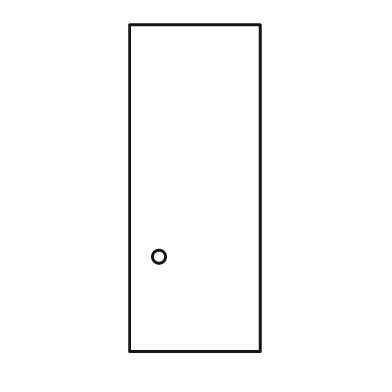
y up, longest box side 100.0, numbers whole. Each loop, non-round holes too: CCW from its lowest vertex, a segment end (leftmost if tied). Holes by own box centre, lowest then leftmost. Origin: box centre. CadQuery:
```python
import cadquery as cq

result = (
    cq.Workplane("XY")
    .moveTo(-20.0, -50.0)
    .lineTo(20.0, -50.0)
    .lineTo(20.0, 50.0)
    .lineTo(-20.0, 50.0)
    .close()
    .moveTo(-11.0, -21.0)
    .circle(2.0)
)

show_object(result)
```